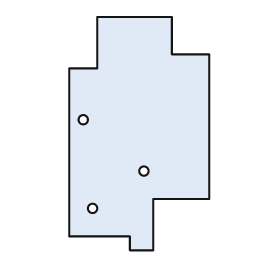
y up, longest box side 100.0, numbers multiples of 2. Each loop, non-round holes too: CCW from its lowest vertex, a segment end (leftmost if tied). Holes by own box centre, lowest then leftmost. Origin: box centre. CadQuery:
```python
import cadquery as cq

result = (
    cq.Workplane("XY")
    .moveTo(-4.0, -50.0)
    .lineTo(6.0, -50.0)
    .lineTo(6.0, -28.0)
    .lineTo(30.0, -28.0)
    .lineTo(30.0, 34.0)
    .lineTo(14.0, 34.0)
    .lineTo(14.0, 50.0)
    .lineTo(-18.0, 50.0)
    .lineTo(-18.0, 28.0)
    .lineTo(-30.0, 28.0)
    .lineTo(-30.0, -44.0)
    .lineTo(-4.0, -44.0)
    .close()
    .moveTo(-20.0, -32.0)
    .circle(2.0)
    .moveTo(2.0, -16.0)
    .circle(2.0)
    .moveTo(-24.0, 6.0)
    .circle(2.0)
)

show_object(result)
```